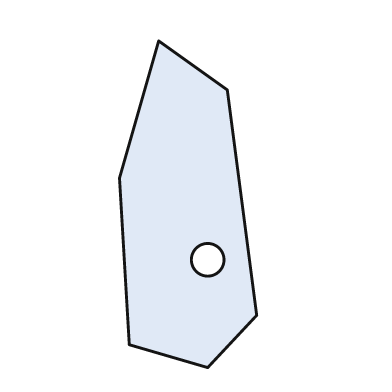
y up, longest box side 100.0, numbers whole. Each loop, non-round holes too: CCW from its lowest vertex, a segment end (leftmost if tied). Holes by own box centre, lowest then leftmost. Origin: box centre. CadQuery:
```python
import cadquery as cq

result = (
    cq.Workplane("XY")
    .moveTo(6.0, -50.0)
    .lineTo(21.0, -34.0)
    .lineTo(12.0, 35.0)
    .lineTo(-9.0, 50.0)
    .lineTo(-21.0, 8.0)
    .lineTo(-18.0, -43.0)
    .close()
    .moveTo(6.0, -17.0)
    .circle(5.0)
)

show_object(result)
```